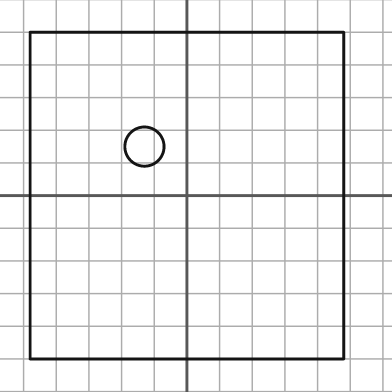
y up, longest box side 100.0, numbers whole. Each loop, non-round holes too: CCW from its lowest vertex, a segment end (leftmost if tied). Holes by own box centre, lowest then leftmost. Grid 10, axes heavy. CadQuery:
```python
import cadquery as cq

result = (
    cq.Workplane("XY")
    .moveTo(-48.0, -50.0)
    .lineTo(48.0, -50.0)
    .lineTo(48.0, 50.0)
    .lineTo(-48.0, 50.0)
    .close()
    .moveTo(-13.0, 15.0)
    .circle(6.0)
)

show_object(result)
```